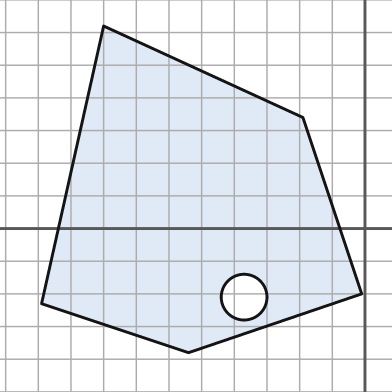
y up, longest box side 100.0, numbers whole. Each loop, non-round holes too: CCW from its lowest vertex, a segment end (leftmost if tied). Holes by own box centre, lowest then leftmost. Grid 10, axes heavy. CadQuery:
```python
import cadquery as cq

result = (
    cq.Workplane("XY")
    .moveTo(-54.0, -38.0)
    .lineTo(-1.0, -20.0)
    .lineTo(-19.0, 34.0)
    .lineTo(-80.0, 62.0)
    .lineTo(-99.0, -23.0)
    .close()
    .moveTo(-37.0, -21.0)
    .circle(7.0)
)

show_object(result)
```